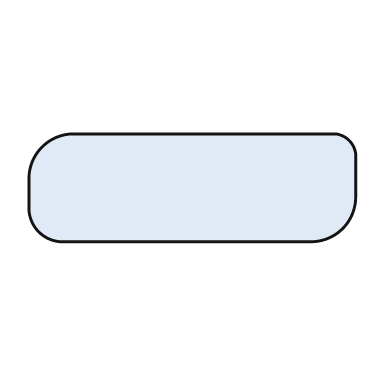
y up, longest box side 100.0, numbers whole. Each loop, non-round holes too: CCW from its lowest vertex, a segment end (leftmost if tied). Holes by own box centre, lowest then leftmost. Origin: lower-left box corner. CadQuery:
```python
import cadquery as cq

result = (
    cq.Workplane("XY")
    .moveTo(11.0, 0.0)
    .lineTo(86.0, 0.0)
    .threePointArc((96.0, 4.0), (100.0, 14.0))
    .lineTo(100.0, 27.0)
    .threePointArc((98.0, 31.0), (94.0, 33.0))
    .lineTo(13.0, 33.0)
    .threePointArc((4.0, 29.0), (0.0, 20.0))
    .lineTo(0.0, 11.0)
    .threePointArc((3.0, 3.0), (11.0, 0.0))
    .close()
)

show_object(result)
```